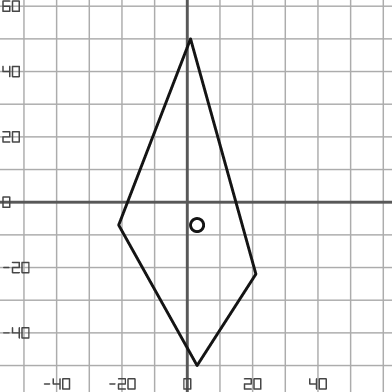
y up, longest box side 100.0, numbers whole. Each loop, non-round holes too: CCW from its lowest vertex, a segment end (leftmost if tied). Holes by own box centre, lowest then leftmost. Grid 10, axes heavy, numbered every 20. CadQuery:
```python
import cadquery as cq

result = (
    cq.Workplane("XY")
    .moveTo(3.0, -50.0)
    .lineTo(21.0, -22.0)
    .lineTo(1.0, 50.0)
    .lineTo(-21.0, -7.0)
    .close()
    .moveTo(3.0, -7.0)
    .circle(2.0)
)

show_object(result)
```